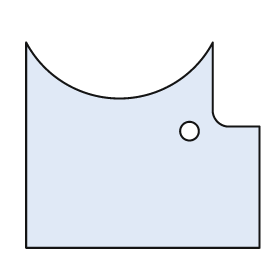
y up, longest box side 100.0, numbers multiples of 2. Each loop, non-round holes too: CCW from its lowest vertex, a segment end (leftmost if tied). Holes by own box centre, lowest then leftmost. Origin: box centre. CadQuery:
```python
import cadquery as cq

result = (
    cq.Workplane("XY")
    .moveTo(-50.0, -44.0)
    .lineTo(50.0, -44.0)
    .lineTo(50.0, 8.0)
    .lineTo(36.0, 8.0)
    .threePointArc((32.0, 10.0), (30.0, 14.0))
    .lineTo(30.0, 44.0)
    .threePointArc((-10.0, 20.0), (-50.0, 44.0))
    .close()
    .moveTo(20.0, 6.0)
    .circle(4.0)
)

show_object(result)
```